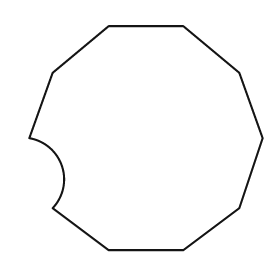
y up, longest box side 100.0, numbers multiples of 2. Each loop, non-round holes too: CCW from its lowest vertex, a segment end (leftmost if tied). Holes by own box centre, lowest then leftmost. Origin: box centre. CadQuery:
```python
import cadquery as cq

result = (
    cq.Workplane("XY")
    .moveTo(-16.0, -48.0)
    .lineTo(16.0, -48.0)
    .lineTo(40.0, -30.0)
    .lineTo(50.0, 0.0)
    .lineTo(40.0, 28.0)
    .lineTo(16.0, 48.0)
    .lineTo(-16.0, 48.0)
    .lineTo(-40.0, 28.0)
    .lineTo(-50.0, 0.0)
    .threePointArc((-36.0, -12.0), (-40.0, -30.0))
    .close()
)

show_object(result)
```